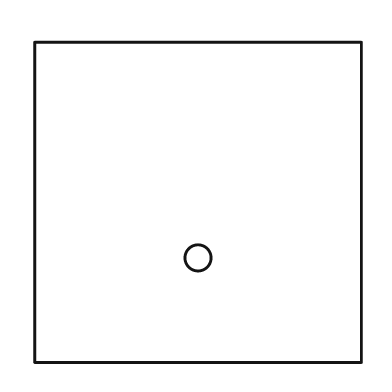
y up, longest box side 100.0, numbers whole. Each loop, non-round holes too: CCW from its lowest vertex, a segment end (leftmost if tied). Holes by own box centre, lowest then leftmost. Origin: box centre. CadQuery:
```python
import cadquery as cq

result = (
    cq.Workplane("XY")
    .moveTo(-50.0, -49.0)
    .lineTo(50.0, -49.0)
    .lineTo(50.0, 49.0)
    .lineTo(-50.0, 49.0)
    .close()
    .moveTo(0.0, -17.0)
    .circle(4.0)
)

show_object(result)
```